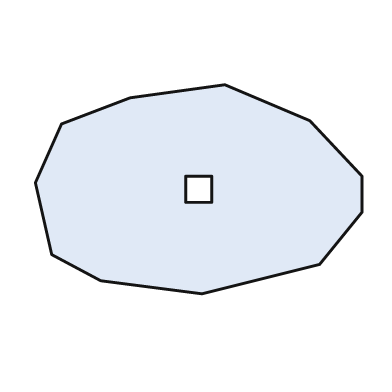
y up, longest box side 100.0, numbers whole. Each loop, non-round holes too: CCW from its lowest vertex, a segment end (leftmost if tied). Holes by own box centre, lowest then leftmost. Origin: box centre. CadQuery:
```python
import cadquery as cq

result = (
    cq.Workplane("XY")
    .moveTo(1.0, -32.0)
    .lineTo(37.0, -23.0)
    .lineTo(50.0, -7.0)
    .lineTo(50.0, 4.0)
    .lineTo(34.0, 21.0)
    .lineTo(8.0, 32.0)
    .lineTo(-21.0, 28.0)
    .lineTo(-42.0, 20.0)
    .lineTo(-50.0, 2.0)
    .lineTo(-45.0, -20.0)
    .lineTo(-30.0, -28.0)
    .close()
    .moveTo(-4.0, -4.0)
    .lineTo(4.0, -4.0)
    .lineTo(4.0, 4.0)
    .lineTo(-4.0, 4.0)
    .close()
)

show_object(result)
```